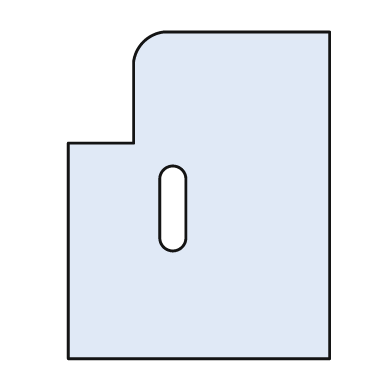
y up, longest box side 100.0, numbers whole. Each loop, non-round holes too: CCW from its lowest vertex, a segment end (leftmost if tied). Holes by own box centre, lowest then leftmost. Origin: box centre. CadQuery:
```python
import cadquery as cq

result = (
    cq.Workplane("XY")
    .moveTo(-40.0, -50.0)
    .lineTo(40.0, -50.0)
    .lineTo(40.0, 50.0)
    .lineTo(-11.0, 50.0)
    .threePointArc((-17.0, 47.0), (-20.0, 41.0))
    .lineTo(-20.0, 16.0)
    .lineTo(-40.0, 16.0)
    .close()
    .moveTo(-12.0, -13.0)
    .threePointArc((-8.0, -17.0), (-4.0, -13.0))
    .lineTo(-4.0, 5.0)
    .threePointArc((-8.0, 9.0), (-12.0, 5.0))
    .close()
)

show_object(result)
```